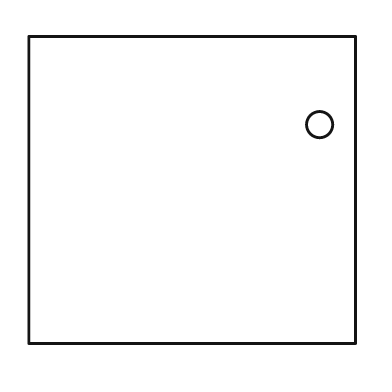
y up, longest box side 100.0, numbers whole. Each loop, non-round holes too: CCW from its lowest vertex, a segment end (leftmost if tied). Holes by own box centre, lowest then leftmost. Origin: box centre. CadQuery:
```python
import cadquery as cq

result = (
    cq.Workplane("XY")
    .moveTo(-50.0, -47.0)
    .lineTo(50.0, -47.0)
    .lineTo(50.0, 47.0)
    .lineTo(-50.0, 47.0)
    .close()
    .moveTo(39.0, 20.0)
    .circle(4.0)
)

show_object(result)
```